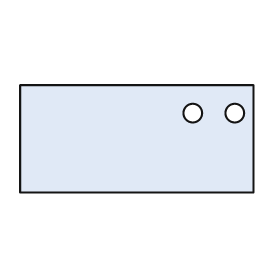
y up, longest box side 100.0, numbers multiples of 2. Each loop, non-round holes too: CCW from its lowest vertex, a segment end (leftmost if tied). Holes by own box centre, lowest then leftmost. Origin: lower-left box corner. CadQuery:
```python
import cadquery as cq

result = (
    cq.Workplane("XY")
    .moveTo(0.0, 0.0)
    .lineTo(100.0, 0.0)
    .lineTo(100.0, 46.0)
    .lineTo(0.0, 46.0)
    .close()
    .moveTo(74.0, 34.0)
    .circle(4.0)
    .moveTo(92.0, 34.0)
    .circle(4.0)
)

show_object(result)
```